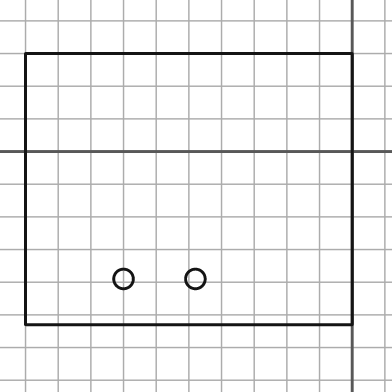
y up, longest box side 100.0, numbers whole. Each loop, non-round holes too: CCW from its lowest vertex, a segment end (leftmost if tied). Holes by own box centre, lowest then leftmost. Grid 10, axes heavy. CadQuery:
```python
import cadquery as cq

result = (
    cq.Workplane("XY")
    .moveTo(-100.0, -53.0)
    .lineTo(0.0, -53.0)
    .lineTo(0.0, 30.0)
    .lineTo(-100.0, 30.0)
    .close()
    .moveTo(-70.0, -39.0)
    .circle(3.0)
    .moveTo(-48.0, -39.0)
    .circle(3.0)
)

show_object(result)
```